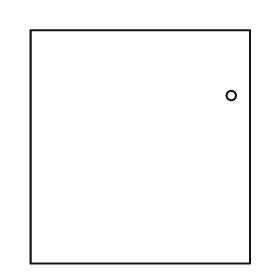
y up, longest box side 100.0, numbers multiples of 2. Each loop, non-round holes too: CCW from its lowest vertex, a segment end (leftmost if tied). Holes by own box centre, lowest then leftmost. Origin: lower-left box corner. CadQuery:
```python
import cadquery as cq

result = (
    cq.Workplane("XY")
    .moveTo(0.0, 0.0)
    .lineTo(94.0, 0.0)
    .lineTo(94.0, 100.0)
    .lineTo(0.0, 100.0)
    .close()
    .moveTo(86.0, 72.0)
    .circle(2.0)
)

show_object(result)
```